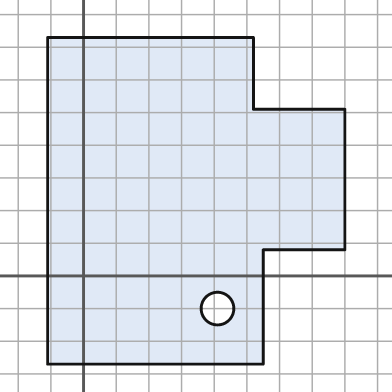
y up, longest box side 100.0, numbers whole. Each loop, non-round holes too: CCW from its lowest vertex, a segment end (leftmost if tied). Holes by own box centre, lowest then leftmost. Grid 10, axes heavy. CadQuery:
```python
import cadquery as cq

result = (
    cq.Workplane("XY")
    .moveTo(-11.0, -27.0)
    .lineTo(55.0, -27.0)
    .lineTo(55.0, 8.0)
    .lineTo(80.0, 8.0)
    .lineTo(80.0, 51.0)
    .lineTo(52.0, 51.0)
    .lineTo(52.0, 73.0)
    .lineTo(-11.0, 73.0)
    .close()
    .moveTo(41.0, -10.0)
    .circle(5.0)
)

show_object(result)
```